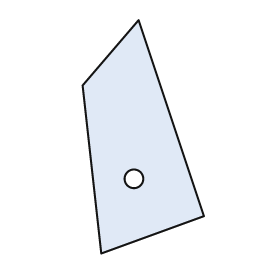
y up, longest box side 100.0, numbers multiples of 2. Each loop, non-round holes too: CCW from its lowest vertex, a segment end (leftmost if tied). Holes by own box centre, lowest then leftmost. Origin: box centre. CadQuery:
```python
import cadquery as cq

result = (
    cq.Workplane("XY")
    .moveTo(-18.0, -50.0)
    .lineTo(26.0, -34.0)
    .lineTo(-2.0, 50.0)
    .lineTo(-26.0, 22.0)
    .close()
    .moveTo(-4.0, -18.0)
    .circle(4.0)
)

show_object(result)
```